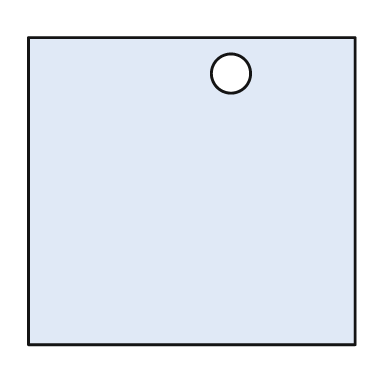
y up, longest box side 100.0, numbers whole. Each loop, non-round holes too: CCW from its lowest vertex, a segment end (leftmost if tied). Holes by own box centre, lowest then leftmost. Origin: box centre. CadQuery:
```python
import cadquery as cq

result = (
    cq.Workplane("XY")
    .moveTo(-50.0, -47.0)
    .lineTo(50.0, -47.0)
    .lineTo(50.0, 47.0)
    .lineTo(-50.0, 47.0)
    .close()
    .moveTo(12.0, 36.0)
    .circle(6.0)
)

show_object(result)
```